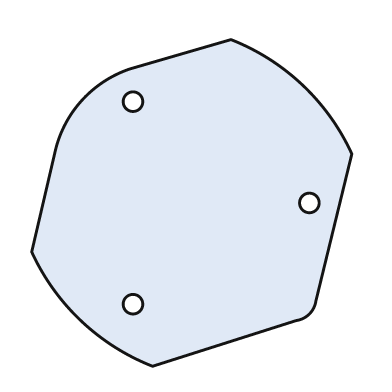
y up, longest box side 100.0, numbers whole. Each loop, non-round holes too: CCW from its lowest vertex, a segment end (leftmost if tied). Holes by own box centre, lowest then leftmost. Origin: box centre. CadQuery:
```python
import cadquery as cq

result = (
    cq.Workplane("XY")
    .moveTo(-12.0, -50.0)
    .lineTo(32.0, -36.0)
    .threePointArc((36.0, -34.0), (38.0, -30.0))
    .lineTo(49.0, 15.0)
    .threePointArc((34.0, 36.0), (12.0, 50.0))
    .lineTo(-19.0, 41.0)
    .threePointArc((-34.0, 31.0), (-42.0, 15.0))
    .lineTo(-49.0, -15.0)
    .threePointArc((-34.0, -36.0), (-12.0, -50.0))
    .close()
    .moveTo(-18.0, -31.0)
    .circle(3.0)
    .moveTo(36.0, 0.0)
    .circle(3.0)
    .moveTo(-18.0, 31.0)
    .circle(3.0)
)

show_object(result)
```